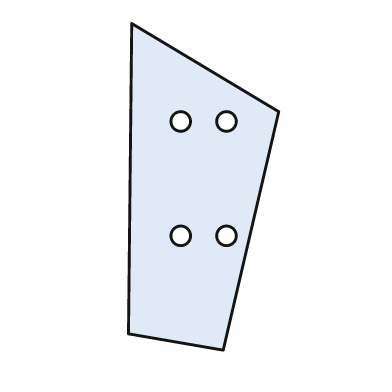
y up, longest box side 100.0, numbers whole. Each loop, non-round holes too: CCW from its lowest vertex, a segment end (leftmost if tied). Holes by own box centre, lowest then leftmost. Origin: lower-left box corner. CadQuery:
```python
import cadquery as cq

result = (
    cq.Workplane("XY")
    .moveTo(29.0, 0.0)
    .lineTo(46.0, 73.0)
    .lineTo(1.0, 100.0)
    .lineTo(0.0, 5.0)
    .close()
    .moveTo(16.0, 35.0)
    .circle(3.0)
    .moveTo(30.0, 35.0)
    .circle(3.0)
    .moveTo(16.0, 70.0)
    .circle(3.0)
    .moveTo(30.0, 70.0)
    .circle(3.0)
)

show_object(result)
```